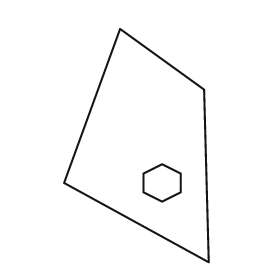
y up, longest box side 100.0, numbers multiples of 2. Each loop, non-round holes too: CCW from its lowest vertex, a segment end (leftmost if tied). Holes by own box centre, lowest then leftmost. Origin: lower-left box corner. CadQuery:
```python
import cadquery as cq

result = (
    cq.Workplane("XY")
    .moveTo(62.0, 0.0)
    .lineTo(60.0, 74.0)
    .lineTo(24.0, 100.0)
    .lineTo(0.0, 34.0)
    .close()
    .moveTo(42.0, 26.0)
    .lineTo(50.0, 30.0)
    .lineTo(50.0, 38.0)
    .lineTo(42.0, 42.0)
    .lineTo(34.0, 38.0)
    .lineTo(34.0, 30.0)
    .close()
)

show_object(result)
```